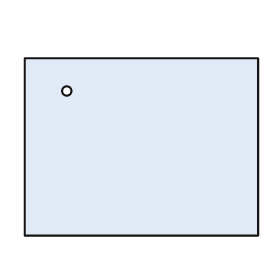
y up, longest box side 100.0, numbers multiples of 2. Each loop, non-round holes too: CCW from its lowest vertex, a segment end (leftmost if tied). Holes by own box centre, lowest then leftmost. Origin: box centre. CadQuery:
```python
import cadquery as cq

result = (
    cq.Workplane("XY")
    .moveTo(-50.0, -38.0)
    .lineTo(50.0, -38.0)
    .lineTo(50.0, 38.0)
    .lineTo(-50.0, 38.0)
    .close()
    .moveTo(-32.0, 24.0)
    .circle(2.0)
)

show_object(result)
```